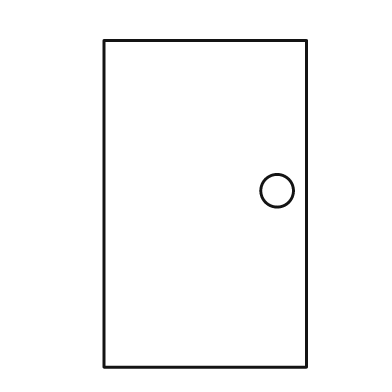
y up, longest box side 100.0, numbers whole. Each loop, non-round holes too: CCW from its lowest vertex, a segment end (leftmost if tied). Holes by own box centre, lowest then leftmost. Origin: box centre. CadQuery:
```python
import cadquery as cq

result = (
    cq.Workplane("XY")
    .moveTo(-31.0, -50.0)
    .lineTo(31.0, -50.0)
    .lineTo(31.0, 50.0)
    .lineTo(-31.0, 50.0)
    .close()
    .moveTo(22.0, 4.0)
    .circle(5.0)
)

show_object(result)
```